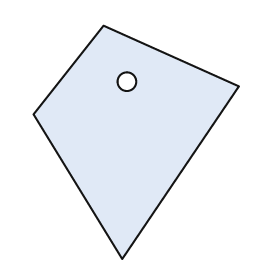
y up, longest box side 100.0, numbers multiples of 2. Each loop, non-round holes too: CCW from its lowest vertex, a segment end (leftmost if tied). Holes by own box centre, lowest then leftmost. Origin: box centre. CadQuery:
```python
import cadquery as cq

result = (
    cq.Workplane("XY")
    .moveTo(-6.0, -50.0)
    .lineTo(44.0, 24.0)
    .lineTo(-14.0, 50.0)
    .lineTo(-44.0, 12.0)
    .close()
    .moveTo(-4.0, 26.0)
    .circle(4.0)
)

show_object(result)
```